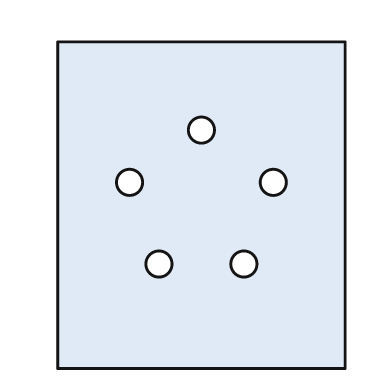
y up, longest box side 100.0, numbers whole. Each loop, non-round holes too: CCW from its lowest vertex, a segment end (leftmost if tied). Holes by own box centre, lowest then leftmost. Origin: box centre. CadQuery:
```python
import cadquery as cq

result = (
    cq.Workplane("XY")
    .moveTo(-44.0, -50.0)
    .lineTo(44.0, -50.0)
    .lineTo(44.0, 50.0)
    .lineTo(-44.0, 50.0)
    .close()
    .moveTo(-13.0, -18.0)
    .circle(4.0)
    .moveTo(13.0, -18.0)
    .circle(4.0)
    .moveTo(-22.0, 7.0)
    .circle(4.0)
    .moveTo(22.0, 7.0)
    .circle(4.0)
    .moveTo(0.0, 23.0)
    .circle(4.0)
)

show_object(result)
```